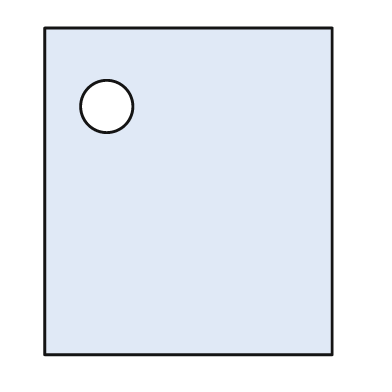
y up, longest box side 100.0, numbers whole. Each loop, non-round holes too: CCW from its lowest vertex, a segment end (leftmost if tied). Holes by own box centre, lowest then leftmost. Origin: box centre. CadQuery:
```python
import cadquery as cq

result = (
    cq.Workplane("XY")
    .moveTo(-44.0, -50.0)
    .lineTo(44.0, -50.0)
    .lineTo(44.0, 50.0)
    .lineTo(-44.0, 50.0)
    .close()
    .moveTo(-25.0, 26.0)
    .circle(8.0)
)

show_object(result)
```